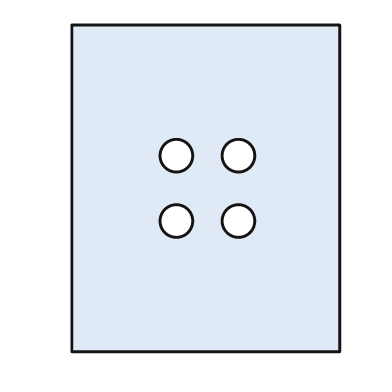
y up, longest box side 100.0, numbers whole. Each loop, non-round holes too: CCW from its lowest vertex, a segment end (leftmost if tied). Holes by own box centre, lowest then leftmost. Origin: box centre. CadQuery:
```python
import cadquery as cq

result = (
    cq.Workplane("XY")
    .moveTo(-41.0, -50.0)
    .lineTo(41.0, -50.0)
    .lineTo(41.0, 50.0)
    .lineTo(-41.0, 50.0)
    .close()
    .moveTo(-9.0, -10.0)
    .circle(5.0)
    .moveTo(10.0, -10.0)
    .circle(5.0)
    .moveTo(-9.0, 10.0)
    .circle(5.0)
    .moveTo(10.0, 10.0)
    .circle(5.0)
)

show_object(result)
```